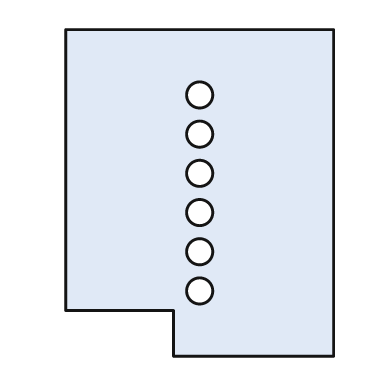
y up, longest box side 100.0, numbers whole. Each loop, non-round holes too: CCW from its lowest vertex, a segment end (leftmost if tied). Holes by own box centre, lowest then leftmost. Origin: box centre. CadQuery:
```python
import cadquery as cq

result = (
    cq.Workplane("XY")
    .moveTo(-8.0, -50.0)
    .lineTo(41.0, -50.0)
    .lineTo(41.0, 50.0)
    .lineTo(-41.0, 50.0)
    .lineTo(-41.0, -36.0)
    .lineTo(-8.0, -36.0)
    .close()
    .moveTo(0.0, -30.0)
    .circle(4.0)
    .moveTo(0.0, -18.0)
    .circle(4.0)
    .moveTo(0.0, -6.0)
    .circle(4.0)
    .moveTo(0.0, 6.0)
    .circle(4.0)
    .moveTo(0.0, 18.0)
    .circle(4.0)
    .moveTo(0.0, 30.0)
    .circle(4.0)
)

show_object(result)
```